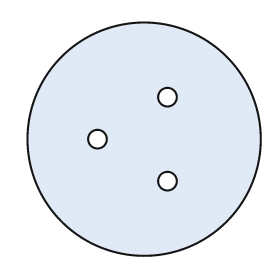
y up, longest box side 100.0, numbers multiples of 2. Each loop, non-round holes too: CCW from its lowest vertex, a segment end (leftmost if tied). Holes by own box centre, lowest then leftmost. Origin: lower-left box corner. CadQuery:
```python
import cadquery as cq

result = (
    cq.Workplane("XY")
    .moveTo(50.0, 50.0)
    .circle(50.0)
    .moveTo(60.0, 32.0)
    .circle(4.0)
    .moveTo(30.0, 50.0)
    .circle(4.0)
    .moveTo(60.0, 68.0)
    .circle(4.0)
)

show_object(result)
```